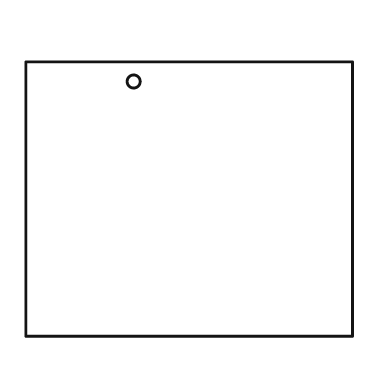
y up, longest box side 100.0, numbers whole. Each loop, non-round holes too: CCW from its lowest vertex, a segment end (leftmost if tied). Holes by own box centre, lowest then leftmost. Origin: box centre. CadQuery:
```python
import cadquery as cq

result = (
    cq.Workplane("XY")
    .moveTo(-50.0, -42.0)
    .lineTo(50.0, -42.0)
    .lineTo(50.0, 42.0)
    .lineTo(-50.0, 42.0)
    .close()
    .moveTo(-17.0, 36.0)
    .circle(2.0)
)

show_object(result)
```